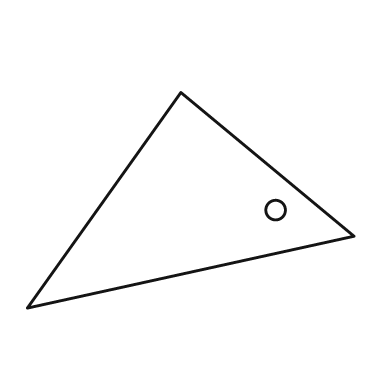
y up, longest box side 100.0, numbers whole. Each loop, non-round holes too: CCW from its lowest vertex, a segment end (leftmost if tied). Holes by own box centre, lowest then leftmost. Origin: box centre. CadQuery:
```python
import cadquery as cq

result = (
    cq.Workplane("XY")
    .moveTo(-50.0, -33.0)
    .lineTo(50.0, -11.0)
    .lineTo(-3.0, 33.0)
    .close()
    .moveTo(26.0, -3.0)
    .circle(3.0)
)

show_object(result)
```